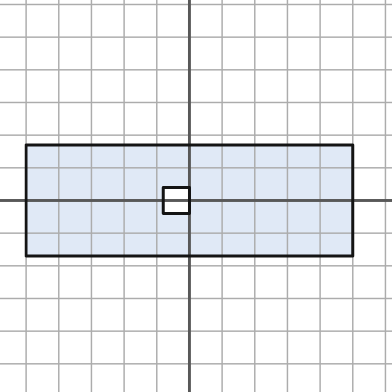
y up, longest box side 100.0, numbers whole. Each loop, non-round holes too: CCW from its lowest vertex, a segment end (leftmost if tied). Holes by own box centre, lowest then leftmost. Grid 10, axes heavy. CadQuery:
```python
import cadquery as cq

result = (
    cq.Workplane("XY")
    .moveTo(-50.0, -17.0)
    .lineTo(50.0, -17.0)
    .lineTo(50.0, 17.0)
    .lineTo(-50.0, 17.0)
    .close()
    .moveTo(-8.0, -4.0)
    .lineTo(0.0, -4.0)
    .lineTo(0.0, 4.0)
    .lineTo(-8.0, 4.0)
    .close()
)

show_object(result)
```